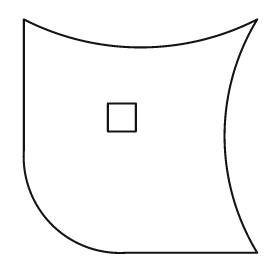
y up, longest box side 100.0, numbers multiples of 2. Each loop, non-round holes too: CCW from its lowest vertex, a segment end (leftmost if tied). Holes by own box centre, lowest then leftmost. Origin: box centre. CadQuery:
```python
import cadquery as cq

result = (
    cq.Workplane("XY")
    .moveTo(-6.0, -50.0)
    .lineTo(50.0, -50.0)
    .threePointArc((36.0, 0.0), (50.0, 50.0))
    .threePointArc((0.0, 38.0), (-50.0, 50.0))
    .lineTo(-50.0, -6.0)
    .threePointArc((-38.0, -38.0), (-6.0, -50.0))
    .close()
    .moveTo(-14.0, 2.0)
    .lineTo(-2.0, 2.0)
    .lineTo(-2.0, 14.0)
    .lineTo(-14.0, 14.0)
    .close()
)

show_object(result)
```